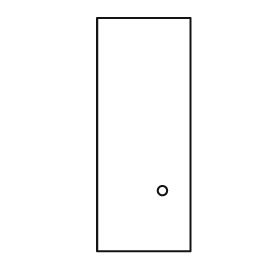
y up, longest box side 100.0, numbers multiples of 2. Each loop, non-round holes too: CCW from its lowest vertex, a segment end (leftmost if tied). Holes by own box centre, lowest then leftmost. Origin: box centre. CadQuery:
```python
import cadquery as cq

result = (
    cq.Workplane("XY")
    .moveTo(-20.0, -50.0)
    .lineTo(20.0, -50.0)
    .lineTo(20.0, 50.0)
    .lineTo(-20.0, 50.0)
    .close()
    .moveTo(8.0, -24.0)
    .circle(2.0)
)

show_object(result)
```